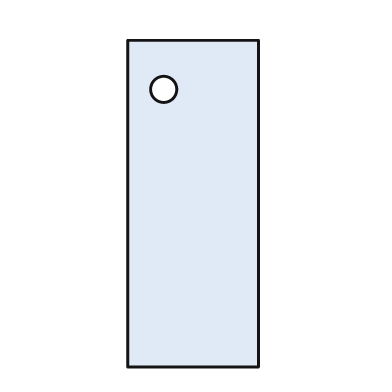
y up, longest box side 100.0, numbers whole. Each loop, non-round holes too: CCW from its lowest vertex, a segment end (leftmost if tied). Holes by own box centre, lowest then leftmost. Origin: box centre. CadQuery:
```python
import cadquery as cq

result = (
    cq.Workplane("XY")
    .moveTo(-20.0, -50.0)
    .lineTo(20.0, -50.0)
    .lineTo(20.0, 50.0)
    .lineTo(-20.0, 50.0)
    .close()
    .moveTo(-9.0, 35.0)
    .circle(4.0)
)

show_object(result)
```